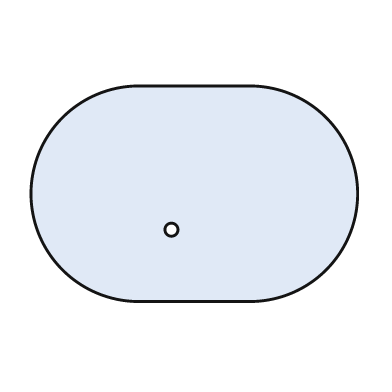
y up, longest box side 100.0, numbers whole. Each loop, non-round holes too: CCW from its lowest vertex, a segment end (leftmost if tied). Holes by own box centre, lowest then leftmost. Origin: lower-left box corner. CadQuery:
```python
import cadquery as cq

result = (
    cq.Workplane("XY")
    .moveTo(33.0, 0.0)
    .lineTo(67.0, 0.0)
    .threePointArc((100.0, 33.0), (67.0, 66.0))
    .lineTo(33.0, 66.0)
    .threePointArc((0.0, 33.0), (33.0, 0.0))
    .close()
    .moveTo(43.0, 22.0)
    .circle(2.0)
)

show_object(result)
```